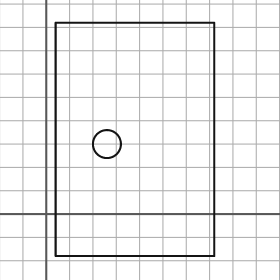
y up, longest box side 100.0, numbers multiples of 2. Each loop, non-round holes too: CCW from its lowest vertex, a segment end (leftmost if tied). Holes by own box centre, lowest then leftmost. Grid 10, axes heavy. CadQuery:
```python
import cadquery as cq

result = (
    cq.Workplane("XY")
    .moveTo(4.0, -18.0)
    .lineTo(72.0, -18.0)
    .lineTo(72.0, 82.0)
    .lineTo(4.0, 82.0)
    .close()
    .moveTo(26.0, 30.0)
    .circle(6.0)
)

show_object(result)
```